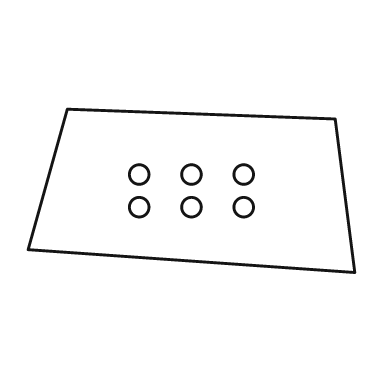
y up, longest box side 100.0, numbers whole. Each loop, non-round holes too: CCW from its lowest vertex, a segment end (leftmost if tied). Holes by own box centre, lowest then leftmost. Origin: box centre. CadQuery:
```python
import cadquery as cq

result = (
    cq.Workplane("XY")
    .moveTo(50.0, -25.0)
    .lineTo(44.0, 22.0)
    .lineTo(-38.0, 25.0)
    .lineTo(-50.0, -18.0)
    .close()
    .moveTo(-16.0, -5.0)
    .circle(3.0)
    .moveTo(0.0, -5.0)
    .circle(3.0)
    .moveTo(16.0, -5.0)
    .circle(3.0)
    .moveTo(-16.0, 5.0)
    .circle(3.0)
    .moveTo(0.0, 5.0)
    .circle(3.0)
    .moveTo(16.0, 5.0)
    .circle(3.0)
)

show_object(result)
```